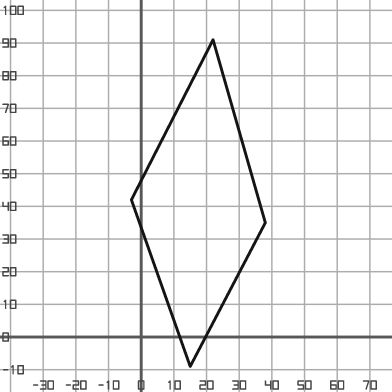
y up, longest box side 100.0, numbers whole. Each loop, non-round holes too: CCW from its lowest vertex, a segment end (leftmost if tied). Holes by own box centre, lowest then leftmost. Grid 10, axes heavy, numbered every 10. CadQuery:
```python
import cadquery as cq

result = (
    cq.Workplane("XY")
    .moveTo(15.0, -9.0)
    .lineTo(38.0, 35.0)
    .lineTo(22.0, 91.0)
    .lineTo(-3.0, 42.0)
    .close()
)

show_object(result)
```